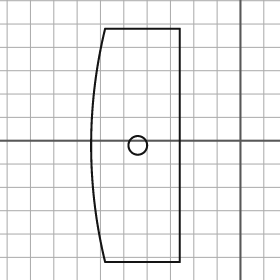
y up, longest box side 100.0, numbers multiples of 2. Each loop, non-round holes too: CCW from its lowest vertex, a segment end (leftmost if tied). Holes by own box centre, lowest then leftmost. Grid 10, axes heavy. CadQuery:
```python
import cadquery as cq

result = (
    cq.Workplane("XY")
    .moveTo(-58.0, -52.0)
    .lineTo(-26.0, -52.0)
    .lineTo(-26.0, 48.0)
    .lineTo(-58.0, 48.0)
    .threePointArc((-64.0, -2.0), (-58.0, -52.0))
    .close()
    .moveTo(-44.0, -2.0)
    .circle(4.0)
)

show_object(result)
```